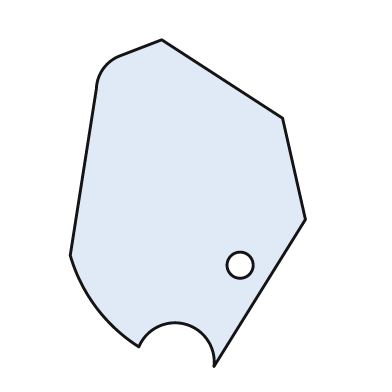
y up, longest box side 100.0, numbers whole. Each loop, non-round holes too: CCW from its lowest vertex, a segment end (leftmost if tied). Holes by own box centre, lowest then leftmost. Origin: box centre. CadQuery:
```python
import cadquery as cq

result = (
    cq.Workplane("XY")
    .moveTo(8.0, -50.0)
    .lineTo(36.0, -5.0)
    .lineTo(29.0, 26.0)
    .lineTo(-8.0, 50.0)
    .lineTo(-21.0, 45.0)
    .threePointArc((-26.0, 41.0), (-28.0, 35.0))
    .lineTo(-36.0, -16.0)
    .threePointArc((-28.0, -32.0), (-15.0, -44.0))
    .threePointArc((-1.0, -37.0), (8.0, -50.0))
    .close()
    .moveTo(16.0, -19.0)
    .circle(4.0)
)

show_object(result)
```